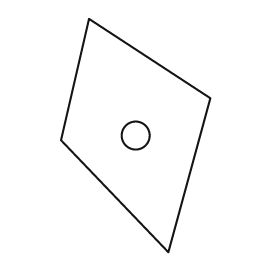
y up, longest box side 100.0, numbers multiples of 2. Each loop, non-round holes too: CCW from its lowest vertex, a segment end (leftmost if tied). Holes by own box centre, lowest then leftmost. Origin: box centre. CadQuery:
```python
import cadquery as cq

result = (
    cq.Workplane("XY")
    .moveTo(14.0, -50.0)
    .lineTo(32.0, 16.0)
    .lineTo(-20.0, 50.0)
    .lineTo(-32.0, -2.0)
    .close()
    .moveTo(0.0, 0.0)
    .circle(6.0)
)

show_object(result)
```